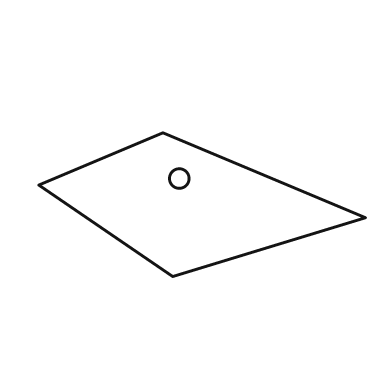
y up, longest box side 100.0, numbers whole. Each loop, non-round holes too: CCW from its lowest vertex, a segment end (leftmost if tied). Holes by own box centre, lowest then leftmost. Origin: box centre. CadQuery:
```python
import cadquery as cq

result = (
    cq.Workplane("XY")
    .moveTo(-9.0, -22.0)
    .lineTo(50.0, -4.0)
    .lineTo(-12.0, 22.0)
    .lineTo(-50.0, 6.0)
    .close()
    .moveTo(-7.0, 8.0)
    .circle(3.0)
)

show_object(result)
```